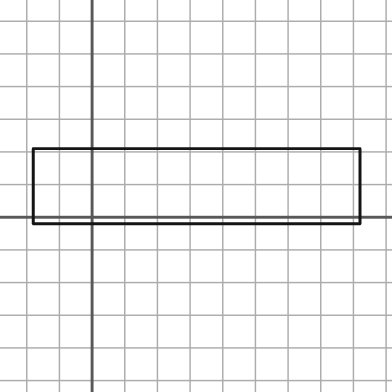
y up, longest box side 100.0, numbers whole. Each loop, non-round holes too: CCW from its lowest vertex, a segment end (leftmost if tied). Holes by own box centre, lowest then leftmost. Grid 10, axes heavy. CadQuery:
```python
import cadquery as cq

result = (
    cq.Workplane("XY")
    .moveTo(-18.0, -2.0)
    .lineTo(82.0, -2.0)
    .lineTo(82.0, 21.0)
    .lineTo(-18.0, 21.0)
    .close()
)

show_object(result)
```